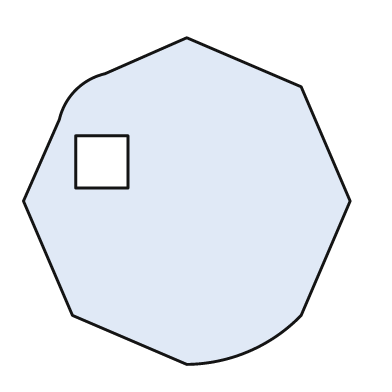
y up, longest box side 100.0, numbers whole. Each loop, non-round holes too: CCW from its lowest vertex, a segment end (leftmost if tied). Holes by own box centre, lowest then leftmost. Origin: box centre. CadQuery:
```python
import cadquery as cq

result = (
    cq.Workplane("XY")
    .moveTo(0.0, -50.0)
    .threePointArc((19.0, -46.0), (35.0, -35.0))
    .lineTo(50.0, 0.0)
    .lineTo(35.0, 35.0)
    .lineTo(0.0, 50.0)
    .lineTo(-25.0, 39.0)
    .threePointArc((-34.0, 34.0), (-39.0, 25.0))
    .lineTo(-50.0, 0.0)
    .lineTo(-35.0, -35.0)
    .close()
    .moveTo(-34.0, 4.0)
    .lineTo(-18.0, 4.0)
    .lineTo(-18.0, 20.0)
    .lineTo(-34.0, 20.0)
    .close()
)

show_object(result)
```